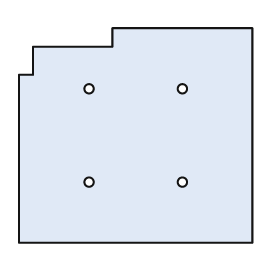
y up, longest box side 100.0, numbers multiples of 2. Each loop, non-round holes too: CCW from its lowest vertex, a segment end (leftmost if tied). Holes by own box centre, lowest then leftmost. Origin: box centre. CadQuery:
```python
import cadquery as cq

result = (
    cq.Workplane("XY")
    .moveTo(-50.0, -46.0)
    .lineTo(50.0, -46.0)
    .lineTo(50.0, 46.0)
    .lineTo(-10.0, 46.0)
    .lineTo(-10.0, 38.0)
    .lineTo(-44.0, 38.0)
    .lineTo(-44.0, 26.0)
    .lineTo(-50.0, 26.0)
    .close()
    .moveTo(-20.0, -20.0)
    .circle(2.0)
    .moveTo(20.0, -20.0)
    .circle(2.0)
    .moveTo(-20.0, 20.0)
    .circle(2.0)
    .moveTo(20.0, 20.0)
    .circle(2.0)
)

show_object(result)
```